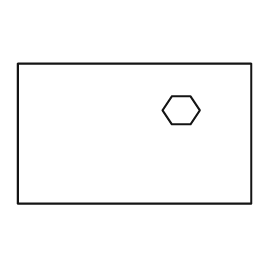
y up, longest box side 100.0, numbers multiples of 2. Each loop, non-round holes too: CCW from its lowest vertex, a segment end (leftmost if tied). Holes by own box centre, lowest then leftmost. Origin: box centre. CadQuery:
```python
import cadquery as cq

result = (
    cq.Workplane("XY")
    .moveTo(-50.0, -30.0)
    .lineTo(50.0, -30.0)
    .lineTo(50.0, 30.0)
    .lineTo(-50.0, 30.0)
    .close()
    .moveTo(16.0, 4.0)
    .lineTo(24.0, 4.0)
    .lineTo(28.0, 10.0)
    .lineTo(24.0, 16.0)
    .lineTo(16.0, 16.0)
    .lineTo(12.0, 10.0)
    .close()
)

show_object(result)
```